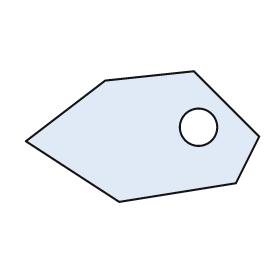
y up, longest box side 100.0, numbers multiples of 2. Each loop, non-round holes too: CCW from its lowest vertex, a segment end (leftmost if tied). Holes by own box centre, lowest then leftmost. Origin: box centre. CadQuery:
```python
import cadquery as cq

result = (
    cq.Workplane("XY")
    .moveTo(-10.0, -28.0)
    .lineTo(40.0, -20.0)
    .lineTo(50.0, 0.0)
    .lineTo(22.0, 28.0)
    .lineTo(-16.0, 24.0)
    .lineTo(-50.0, -2.0)
    .close()
    .moveTo(24.0, 4.0)
    .circle(8.0)
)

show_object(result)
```